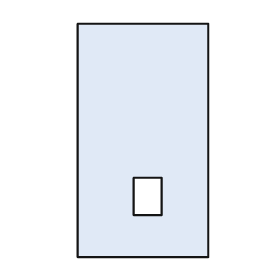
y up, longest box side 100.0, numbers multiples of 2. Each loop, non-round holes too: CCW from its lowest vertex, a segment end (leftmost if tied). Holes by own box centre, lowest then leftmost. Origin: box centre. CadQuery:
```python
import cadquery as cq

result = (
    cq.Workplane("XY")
    .moveTo(-28.0, -50.0)
    .lineTo(28.0, -50.0)
    .lineTo(28.0, 50.0)
    .lineTo(-28.0, 50.0)
    .close()
    .moveTo(-4.0, -32.0)
    .lineTo(8.0, -32.0)
    .lineTo(8.0, -16.0)
    .lineTo(-4.0, -16.0)
    .close()
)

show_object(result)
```